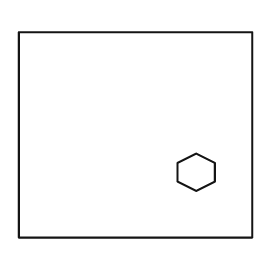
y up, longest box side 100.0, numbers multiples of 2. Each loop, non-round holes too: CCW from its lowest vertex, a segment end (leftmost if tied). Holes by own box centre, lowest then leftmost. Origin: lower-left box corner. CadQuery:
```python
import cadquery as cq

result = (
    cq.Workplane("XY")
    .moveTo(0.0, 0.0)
    .lineTo(100.0, 0.0)
    .lineTo(100.0, 88.0)
    .lineTo(0.0, 88.0)
    .close()
    .moveTo(76.0, 20.0)
    .lineTo(84.0, 24.0)
    .lineTo(84.0, 32.0)
    .lineTo(76.0, 36.0)
    .lineTo(68.0, 32.0)
    .lineTo(68.0, 24.0)
    .close()
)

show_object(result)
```